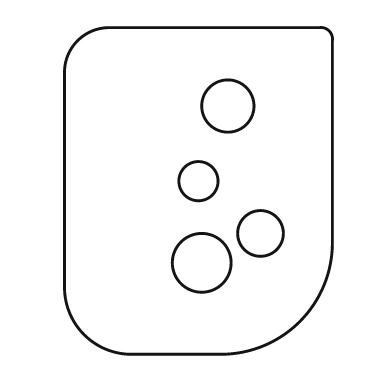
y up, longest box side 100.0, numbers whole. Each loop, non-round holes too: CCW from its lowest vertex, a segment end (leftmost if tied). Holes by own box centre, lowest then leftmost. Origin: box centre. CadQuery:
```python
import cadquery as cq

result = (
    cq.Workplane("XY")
    .moveTo(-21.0, -50.0)
    .lineTo(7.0, -50.0)
    .threePointArc((31.0, -40.0), (41.0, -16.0))
    .lineTo(41.0, 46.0)
    .threePointArc((40.0, 49.0), (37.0, 50.0))
    .lineTo(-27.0, 50.0)
    .threePointArc((-37.0, 46.0), (-41.0, 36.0))
    .lineTo(-41.0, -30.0)
    .threePointArc((-35.0, -44.0), (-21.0, -50.0))
    .close()
    .moveTo(1.0, -22.0)
    .circle(9.0)
    .moveTo(19.0, -13.0)
    .circle(7.0)
    .moveTo(0.0, 3.0)
    .circle(6.0)
    .moveTo(9.0, 26.0)
    .circle(8.0)
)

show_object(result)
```